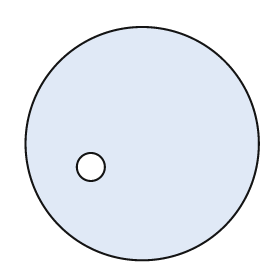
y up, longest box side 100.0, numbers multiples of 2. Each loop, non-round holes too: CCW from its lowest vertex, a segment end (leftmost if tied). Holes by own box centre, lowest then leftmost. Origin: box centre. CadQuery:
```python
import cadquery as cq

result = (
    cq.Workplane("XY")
    .moveTo(0.0, 0.0)
    .circle(50.0)
    .moveTo(-22.0, -10.0)
    .circle(6.0)
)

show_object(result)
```